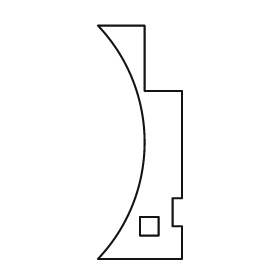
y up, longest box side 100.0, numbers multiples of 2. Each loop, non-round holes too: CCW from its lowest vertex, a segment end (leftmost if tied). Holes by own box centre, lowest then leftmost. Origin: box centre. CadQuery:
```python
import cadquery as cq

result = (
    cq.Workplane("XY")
    .moveTo(-18.0, -50.0)
    .lineTo(18.0, -50.0)
    .lineTo(18.0, -36.0)
    .lineTo(14.0, -36.0)
    .lineTo(14.0, -24.0)
    .lineTo(18.0, -24.0)
    .lineTo(18.0, 22.0)
    .lineTo(2.0, 22.0)
    .lineTo(2.0, 50.0)
    .lineTo(-18.0, 50.0)
    .threePointArc((2.0, 0.0), (-18.0, -50.0))
    .close()
    .moveTo(0.0, -40.0)
    .lineTo(8.0, -40.0)
    .lineTo(8.0, -32.0)
    .lineTo(0.0, -32.0)
    .close()
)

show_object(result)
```